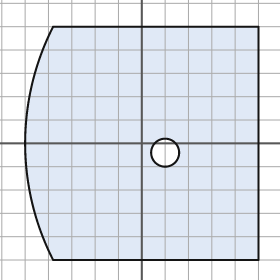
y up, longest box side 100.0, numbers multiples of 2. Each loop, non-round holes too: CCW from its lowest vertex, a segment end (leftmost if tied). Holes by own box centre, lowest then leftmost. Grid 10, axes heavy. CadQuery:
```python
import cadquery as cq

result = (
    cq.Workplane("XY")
    .moveTo(-38.0, -50.0)
    .lineTo(50.0, -50.0)
    .lineTo(50.0, 50.0)
    .lineTo(-38.0, 50.0)
    .threePointArc((-50.0, 0.0), (-38.0, -50.0))
    .close()
    .moveTo(10.0, -4.0)
    .circle(6.0)
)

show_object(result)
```